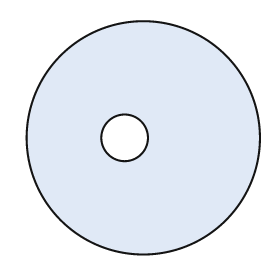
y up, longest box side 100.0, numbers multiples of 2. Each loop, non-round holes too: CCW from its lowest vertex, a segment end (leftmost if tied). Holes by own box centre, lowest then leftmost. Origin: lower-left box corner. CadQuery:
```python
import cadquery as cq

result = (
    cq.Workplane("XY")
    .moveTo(50.0, 50.0)
    .circle(50.0)
    .moveTo(42.0, 50.0)
    .circle(10.0)
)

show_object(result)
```